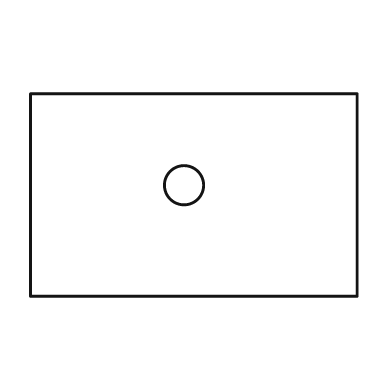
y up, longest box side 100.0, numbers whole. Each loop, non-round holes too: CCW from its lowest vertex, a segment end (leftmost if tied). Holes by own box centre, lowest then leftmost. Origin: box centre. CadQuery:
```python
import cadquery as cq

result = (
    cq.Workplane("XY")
    .moveTo(-50.0, -31.0)
    .lineTo(50.0, -31.0)
    .lineTo(50.0, 31.0)
    .lineTo(-50.0, 31.0)
    .close()
    .moveTo(-3.0, 3.0)
    .circle(6.0)
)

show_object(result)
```